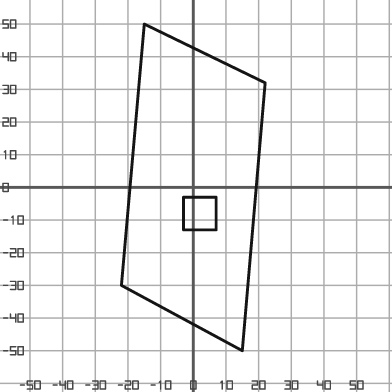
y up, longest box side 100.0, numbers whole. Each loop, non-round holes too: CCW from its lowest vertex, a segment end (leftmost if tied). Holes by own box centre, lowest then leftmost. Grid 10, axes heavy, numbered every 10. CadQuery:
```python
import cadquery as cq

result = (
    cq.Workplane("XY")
    .moveTo(15.0, -50.0)
    .lineTo(22.0, 32.0)
    .lineTo(-15.0, 50.0)
    .lineTo(-22.0, -30.0)
    .close()
    .moveTo(-3.0, -13.0)
    .lineTo(7.0, -13.0)
    .lineTo(7.0, -3.0)
    .lineTo(-3.0, -3.0)
    .close()
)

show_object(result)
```